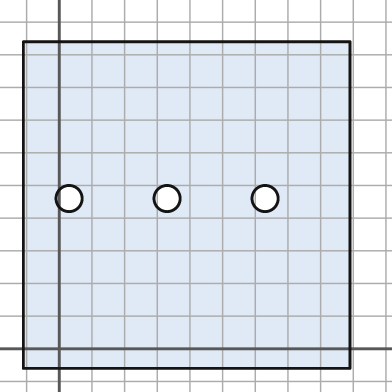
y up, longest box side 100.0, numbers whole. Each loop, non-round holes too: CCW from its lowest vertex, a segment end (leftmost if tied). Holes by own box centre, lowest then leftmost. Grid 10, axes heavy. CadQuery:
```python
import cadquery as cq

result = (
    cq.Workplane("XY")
    .moveTo(-11.0, -6.0)
    .lineTo(89.0, -6.0)
    .lineTo(89.0, 94.0)
    .lineTo(-11.0, 94.0)
    .close()
    .moveTo(3.0, 46.0)
    .circle(4.0)
    .moveTo(33.0, 46.0)
    .circle(4.0)
    .moveTo(63.0, 46.0)
    .circle(4.0)
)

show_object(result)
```